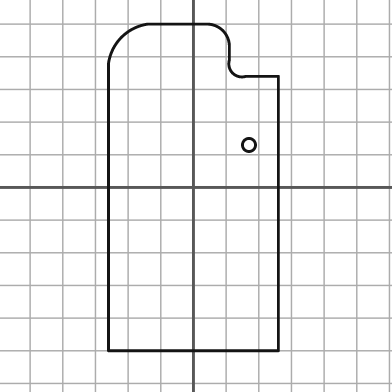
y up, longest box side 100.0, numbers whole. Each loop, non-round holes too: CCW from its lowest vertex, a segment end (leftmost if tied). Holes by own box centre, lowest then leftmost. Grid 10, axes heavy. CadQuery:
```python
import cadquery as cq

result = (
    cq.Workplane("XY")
    .moveTo(-26.0, -50.0)
    .lineTo(26.0, -50.0)
    .lineTo(26.0, 34.0)
    .lineTo(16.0, 34.0)
    .threePointArc((12.0, 35.0), (11.0, 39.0))
    .lineTo(11.0, 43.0)
    .threePointArc((9.0, 48.0), (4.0, 50.0))
    .lineTo(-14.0, 50.0)
    .threePointArc((-22.0, 46.0), (-26.0, 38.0))
    .close()
    .moveTo(17.0, 13.0)
    .circle(2.0)
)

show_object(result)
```